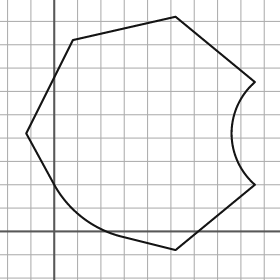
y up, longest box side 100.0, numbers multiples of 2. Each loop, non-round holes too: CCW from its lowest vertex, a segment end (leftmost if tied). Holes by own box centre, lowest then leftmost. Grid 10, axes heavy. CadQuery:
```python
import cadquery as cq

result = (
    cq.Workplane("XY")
    .moveTo(52.0, -8.0)
    .lineTo(86.0, 20.0)
    .threePointArc((76.0, 42.0), (86.0, 64.0))
    .lineTo(52.0, 92.0)
    .lineTo(8.0, 82.0)
    .lineTo(-12.0, 42.0)
    .lineTo(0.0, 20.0)
    .threePointArc((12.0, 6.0), (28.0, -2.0))
    .close()
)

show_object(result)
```